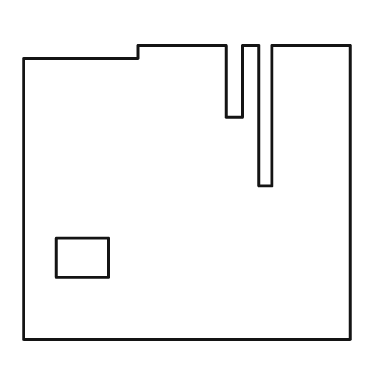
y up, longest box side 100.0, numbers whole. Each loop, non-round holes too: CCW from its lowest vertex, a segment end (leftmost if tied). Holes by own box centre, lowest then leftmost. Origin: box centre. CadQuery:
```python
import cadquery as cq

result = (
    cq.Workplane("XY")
    .moveTo(-50.0, -45.0)
    .lineTo(50.0, -45.0)
    .lineTo(50.0, 45.0)
    .lineTo(26.0, 45.0)
    .lineTo(26.0, 2.0)
    .lineTo(22.0, 2.0)
    .lineTo(22.0, 45.0)
    .lineTo(17.0, 45.0)
    .lineTo(17.0, 23.0)
    .lineTo(12.0, 23.0)
    .lineTo(12.0, 45.0)
    .lineTo(-15.0, 45.0)
    .lineTo(-15.0, 41.0)
    .lineTo(-50.0, 41.0)
    .close()
    .moveTo(-40.0, -26.0)
    .lineTo(-24.0, -26.0)
    .lineTo(-24.0, -14.0)
    .lineTo(-40.0, -14.0)
    .close()
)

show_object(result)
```